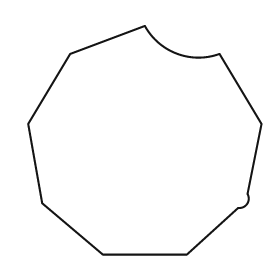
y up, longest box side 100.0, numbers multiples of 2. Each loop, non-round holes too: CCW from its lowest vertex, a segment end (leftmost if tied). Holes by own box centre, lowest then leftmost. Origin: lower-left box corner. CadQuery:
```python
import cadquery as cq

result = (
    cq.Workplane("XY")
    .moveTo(32.0, 0.0)
    .lineTo(68.0, 0.0)
    .lineTo(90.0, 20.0)
    .threePointArc((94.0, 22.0), (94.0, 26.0))
    .lineTo(100.0, 56.0)
    .lineTo(82.0, 86.0)
    .threePointArc((64.0, 86.0), (50.0, 98.0))
    .lineTo(18.0, 86.0)
    .lineTo(0.0, 56.0)
    .lineTo(6.0, 22.0)
    .close()
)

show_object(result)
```